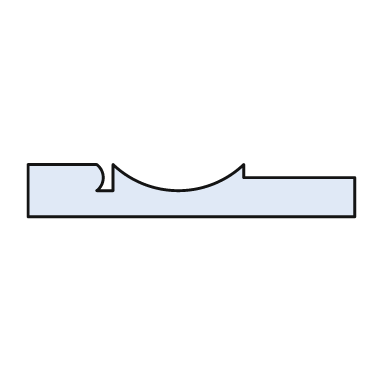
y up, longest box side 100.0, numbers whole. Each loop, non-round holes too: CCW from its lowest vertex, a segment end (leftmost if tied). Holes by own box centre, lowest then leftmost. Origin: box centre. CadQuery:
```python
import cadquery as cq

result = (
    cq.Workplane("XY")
    .moveTo(-50.0, -8.0)
    .lineTo(50.0, -8.0)
    .lineTo(50.0, 4.0)
    .lineTo(16.0, 4.0)
    .lineTo(16.0, 8.0)
    .threePointArc((-4.0, 0.0), (-24.0, 8.0))
    .lineTo(-24.0, 0.0)
    .lineTo(-29.0, 0.0)
    .threePointArc((-27.0, 4.0), (-29.0, 8.0))
    .lineTo(-50.0, 8.0)
    .close()
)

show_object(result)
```